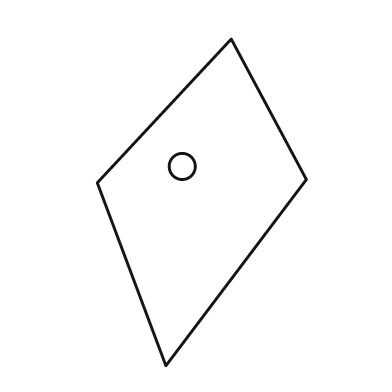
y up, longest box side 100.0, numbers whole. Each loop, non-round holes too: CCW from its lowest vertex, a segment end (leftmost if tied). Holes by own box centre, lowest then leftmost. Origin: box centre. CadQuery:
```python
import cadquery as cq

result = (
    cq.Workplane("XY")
    .moveTo(-11.0, -50.0)
    .lineTo(32.0, 7.0)
    .lineTo(9.0, 50.0)
    .lineTo(-32.0, 6.0)
    .close()
    .moveTo(-6.0, 11.0)
    .circle(4.0)
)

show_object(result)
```